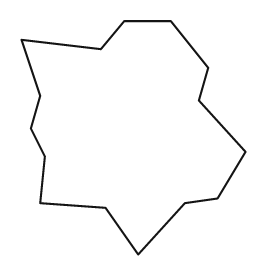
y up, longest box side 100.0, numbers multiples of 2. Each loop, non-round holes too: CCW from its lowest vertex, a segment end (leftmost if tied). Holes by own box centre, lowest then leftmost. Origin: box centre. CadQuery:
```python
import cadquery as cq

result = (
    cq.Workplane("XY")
    .moveTo(2.0, -50.0)
    .lineTo(22.0, -28.0)
    .lineTo(36.0, -26.0)
    .lineTo(48.0, -6.0)
    .lineTo(28.0, 16.0)
    .lineTo(32.0, 30.0)
    .lineTo(16.0, 50.0)
    .lineTo(-4.0, 50.0)
    .lineTo(-14.0, 38.0)
    .lineTo(-48.0, 42.0)
    .lineTo(-40.0, 18.0)
    .lineTo(-44.0, 4.0)
    .lineTo(-38.0, -8.0)
    .lineTo(-40.0, -28.0)
    .lineTo(-12.0, -30.0)
    .close()
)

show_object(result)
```